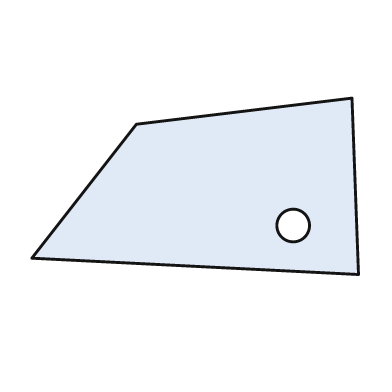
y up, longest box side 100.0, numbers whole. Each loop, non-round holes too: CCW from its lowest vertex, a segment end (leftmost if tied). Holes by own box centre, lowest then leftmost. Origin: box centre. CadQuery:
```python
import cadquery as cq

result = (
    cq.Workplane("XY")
    .moveTo(50.0, -27.0)
    .lineTo(48.0, 27.0)
    .lineTo(-18.0, 19.0)
    .lineTo(-50.0, -22.0)
    .close()
    .moveTo(30.0, -12.0)
    .circle(5.0)
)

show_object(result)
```